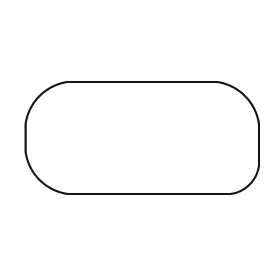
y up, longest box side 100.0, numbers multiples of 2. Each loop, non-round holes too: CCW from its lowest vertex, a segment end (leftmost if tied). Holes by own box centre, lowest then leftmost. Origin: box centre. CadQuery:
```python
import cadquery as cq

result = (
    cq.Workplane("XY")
    .moveTo(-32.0, -24.0)
    .lineTo(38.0, -24.0)
    .threePointArc((46.0, -20.0), (50.0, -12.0))
    .lineTo(50.0, 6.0)
    .threePointArc((44.0, 18.0), (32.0, 24.0))
    .lineTo(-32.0, 24.0)
    .threePointArc((-44.0, 18.0), (-50.0, 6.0))
    .lineTo(-50.0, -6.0)
    .threePointArc((-44.0, -18.0), (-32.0, -24.0))
    .close()
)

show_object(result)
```